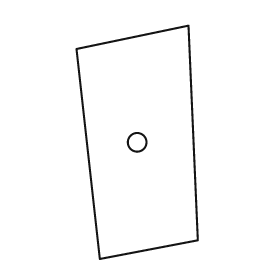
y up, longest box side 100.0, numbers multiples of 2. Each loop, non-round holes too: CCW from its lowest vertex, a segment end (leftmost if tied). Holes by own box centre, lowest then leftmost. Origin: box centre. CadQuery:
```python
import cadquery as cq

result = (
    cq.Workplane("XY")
    .moveTo(-16.0, -50.0)
    .lineTo(26.0, -42.0)
    .lineTo(22.0, 50.0)
    .lineTo(-26.0, 40.0)
    .close()
    .moveTo(0.0, 0.0)
    .circle(4.0)
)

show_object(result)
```